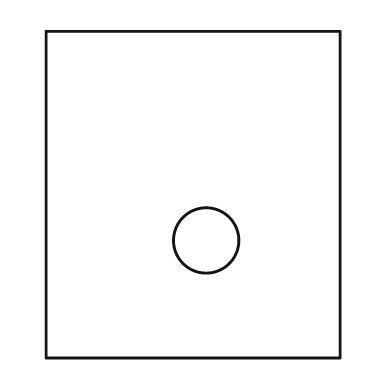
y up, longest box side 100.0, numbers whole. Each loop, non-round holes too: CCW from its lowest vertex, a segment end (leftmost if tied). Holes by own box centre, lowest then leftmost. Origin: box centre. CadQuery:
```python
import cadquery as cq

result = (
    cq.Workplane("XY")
    .moveTo(-45.0, -50.0)
    .lineTo(45.0, -50.0)
    .lineTo(45.0, 50.0)
    .lineTo(-45.0, 50.0)
    .close()
    .moveTo(4.0, -14.0)
    .circle(10.0)
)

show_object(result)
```